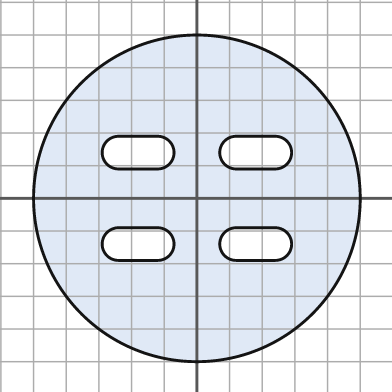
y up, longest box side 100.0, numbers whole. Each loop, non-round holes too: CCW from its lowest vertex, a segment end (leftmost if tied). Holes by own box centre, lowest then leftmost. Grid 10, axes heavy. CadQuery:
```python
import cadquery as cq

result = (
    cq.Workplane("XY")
    .moveTo(0.0, 0.0)
    .circle(50.0)
    .moveTo(-24.0, -19.0)
    .lineTo(-12.0, -19.0)
    .threePointArc((-7.0, -14.0), (-12.0, -9.0))
    .lineTo(-24.0, -9.0)
    .threePointArc((-29.0, -14.0), (-24.0, -19.0))
    .close()
    .moveTo(12.0, -19.0)
    .lineTo(24.0, -19.0)
    .threePointArc((29.0, -14.0), (24.0, -9.0))
    .lineTo(12.0, -9.0)
    .threePointArc((7.0, -14.0), (12.0, -19.0))
    .close()
    .moveTo(-24.0, 9.0)
    .lineTo(-12.0, 9.0)
    .threePointArc((-7.0, 14.0), (-12.0, 19.0))
    .lineTo(-24.0, 19.0)
    .threePointArc((-29.0, 14.0), (-24.0, 9.0))
    .close()
    .moveTo(12.0, 9.0)
    .lineTo(24.0, 9.0)
    .threePointArc((29.0, 14.0), (24.0, 19.0))
    .lineTo(12.0, 19.0)
    .threePointArc((7.0, 14.0), (12.0, 9.0))
    .close()
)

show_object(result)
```